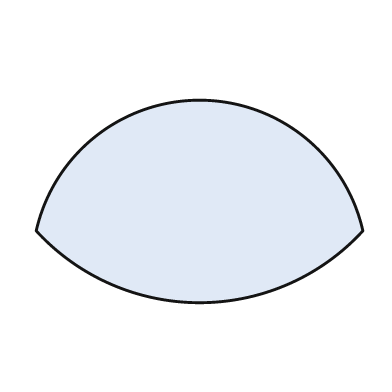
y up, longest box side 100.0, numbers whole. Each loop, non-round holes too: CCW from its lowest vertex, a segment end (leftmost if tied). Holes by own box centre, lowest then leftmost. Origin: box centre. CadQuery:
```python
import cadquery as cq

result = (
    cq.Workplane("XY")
    .moveTo(-50.0, -9.0)
    .threePointArc((0.0, -31.0), (50.0, -9.0))
    .threePointArc((0.0, 31.0), (-50.0, -9.0))
    .close()
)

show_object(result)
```